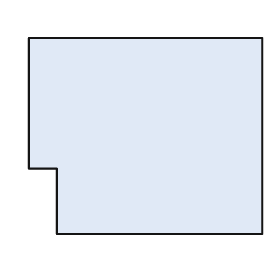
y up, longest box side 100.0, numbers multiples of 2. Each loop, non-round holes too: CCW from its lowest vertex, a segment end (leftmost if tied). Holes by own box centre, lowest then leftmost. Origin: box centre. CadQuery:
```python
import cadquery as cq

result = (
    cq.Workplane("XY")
    .moveTo(-38.0, -42.0)
    .lineTo(50.0, -42.0)
    .lineTo(50.0, 42.0)
    .lineTo(-50.0, 42.0)
    .lineTo(-50.0, -14.0)
    .lineTo(-38.0, -14.0)
    .close()
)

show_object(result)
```